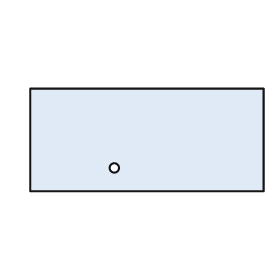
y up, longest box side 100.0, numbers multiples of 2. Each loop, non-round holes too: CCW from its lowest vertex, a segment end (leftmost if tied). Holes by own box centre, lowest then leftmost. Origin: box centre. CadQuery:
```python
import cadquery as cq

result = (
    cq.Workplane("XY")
    .moveTo(-50.0, -22.0)
    .lineTo(50.0, -22.0)
    .lineTo(50.0, 22.0)
    .lineTo(-50.0, 22.0)
    .close()
    .moveTo(-14.0, -12.0)
    .circle(2.0)
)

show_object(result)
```